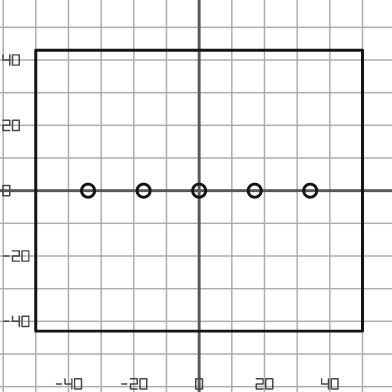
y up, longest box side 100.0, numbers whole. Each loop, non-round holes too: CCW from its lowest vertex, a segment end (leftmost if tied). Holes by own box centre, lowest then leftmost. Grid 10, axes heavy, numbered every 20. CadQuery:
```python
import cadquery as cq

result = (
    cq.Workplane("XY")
    .moveTo(-50.0, -43.0)
    .lineTo(50.0, -43.0)
    .lineTo(50.0, 43.0)
    .lineTo(-50.0, 43.0)
    .close()
    .moveTo(-34.0, 0.0)
    .circle(2.0)
    .moveTo(-17.0, 0.0)
    .circle(2.0)
    .moveTo(0.0, 0.0)
    .circle(2.0)
    .moveTo(17.0, 0.0)
    .circle(2.0)
    .moveTo(34.0, 0.0)
    .circle(2.0)
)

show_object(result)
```